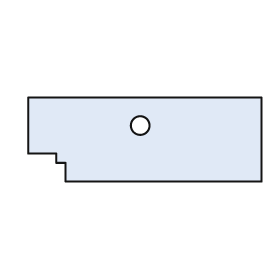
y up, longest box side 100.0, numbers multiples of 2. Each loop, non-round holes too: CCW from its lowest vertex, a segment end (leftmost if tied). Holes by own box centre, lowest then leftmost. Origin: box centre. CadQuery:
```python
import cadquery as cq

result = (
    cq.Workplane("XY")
    .moveTo(-34.0, -18.0)
    .lineTo(50.0, -18.0)
    .lineTo(50.0, 18.0)
    .lineTo(-50.0, 18.0)
    .lineTo(-50.0, -6.0)
    .lineTo(-38.0, -6.0)
    .lineTo(-38.0, -10.0)
    .lineTo(-34.0, -10.0)
    .close()
    .moveTo(-2.0, 6.0)
    .circle(4.0)
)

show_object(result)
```